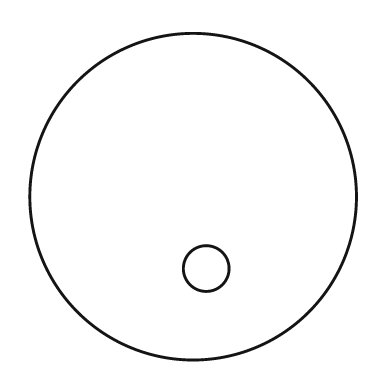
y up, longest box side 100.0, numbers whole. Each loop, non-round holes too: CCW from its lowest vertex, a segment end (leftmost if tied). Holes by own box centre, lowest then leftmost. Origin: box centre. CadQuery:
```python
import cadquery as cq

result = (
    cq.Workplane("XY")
    .moveTo(0.0, 0.0)
    .circle(50.0)
    .moveTo(4.0, -22.0)
    .circle(7.0)
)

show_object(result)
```